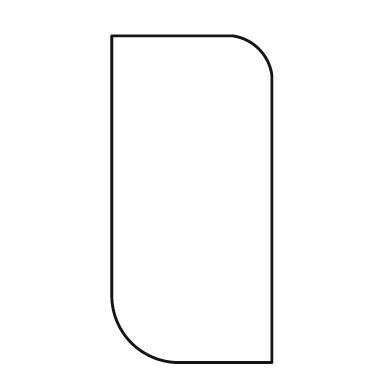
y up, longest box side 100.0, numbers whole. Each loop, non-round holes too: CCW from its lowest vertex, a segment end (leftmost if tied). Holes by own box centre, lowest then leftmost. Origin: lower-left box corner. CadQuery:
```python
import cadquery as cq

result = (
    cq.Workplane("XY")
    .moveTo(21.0, 0.0)
    .lineTo(49.0, 0.0)
    .lineTo(49.0, 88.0)
    .threePointArc((45.0, 96.0), (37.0, 100.0))
    .lineTo(0.0, 100.0)
    .lineTo(0.0, 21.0)
    .threePointArc((6.0, 6.0), (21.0, 0.0))
    .close()
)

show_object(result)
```